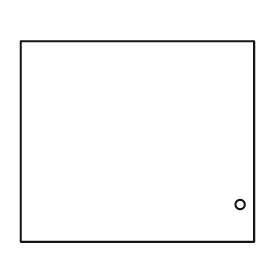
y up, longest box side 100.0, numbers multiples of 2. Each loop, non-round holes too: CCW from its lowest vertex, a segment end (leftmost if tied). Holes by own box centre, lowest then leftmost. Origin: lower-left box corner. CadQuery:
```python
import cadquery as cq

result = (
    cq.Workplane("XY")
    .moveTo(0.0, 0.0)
    .lineTo(100.0, 0.0)
    .lineTo(100.0, 86.0)
    .lineTo(0.0, 86.0)
    .close()
    .moveTo(94.0, 16.0)
    .circle(2.0)
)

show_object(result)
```